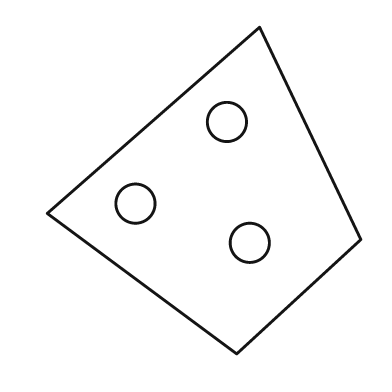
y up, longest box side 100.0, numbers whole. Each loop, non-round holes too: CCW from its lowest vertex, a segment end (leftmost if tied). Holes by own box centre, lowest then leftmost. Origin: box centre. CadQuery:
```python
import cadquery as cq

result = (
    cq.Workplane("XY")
    .moveTo(10.0, -50.0)
    .lineTo(48.0, -15.0)
    .lineTo(17.0, 50.0)
    .lineTo(-48.0, -7.0)
    .close()
    .moveTo(14.0, -16.0)
    .circle(6.0)
    .moveTo(-21.0, -4.0)
    .circle(6.0)
    .moveTo(7.0, 21.0)
    .circle(6.0)
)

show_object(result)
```